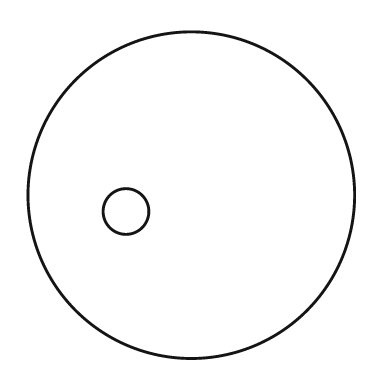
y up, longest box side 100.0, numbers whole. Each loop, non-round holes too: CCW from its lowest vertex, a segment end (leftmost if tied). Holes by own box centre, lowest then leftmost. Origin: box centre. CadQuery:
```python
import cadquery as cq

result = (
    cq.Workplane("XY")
    .moveTo(0.0, 0.0)
    .circle(50.0)
    .moveTo(-20.0, -5.0)
    .circle(7.0)
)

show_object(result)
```